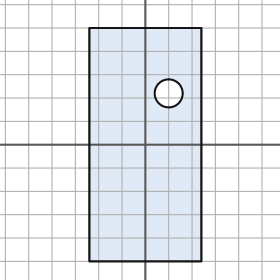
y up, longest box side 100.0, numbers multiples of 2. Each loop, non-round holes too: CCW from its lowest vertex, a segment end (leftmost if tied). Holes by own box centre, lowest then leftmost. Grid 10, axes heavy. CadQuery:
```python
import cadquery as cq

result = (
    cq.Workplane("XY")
    .moveTo(-24.0, -50.0)
    .lineTo(24.0, -50.0)
    .lineTo(24.0, 50.0)
    .lineTo(-24.0, 50.0)
    .close()
    .moveTo(10.0, 22.0)
    .circle(6.0)
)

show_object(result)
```